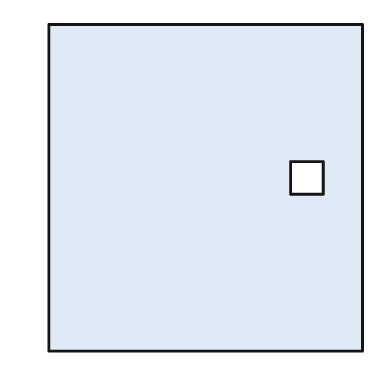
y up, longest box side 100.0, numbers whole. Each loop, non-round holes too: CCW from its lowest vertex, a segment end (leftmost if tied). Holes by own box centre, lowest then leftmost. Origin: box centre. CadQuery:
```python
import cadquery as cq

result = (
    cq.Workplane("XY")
    .moveTo(-48.0, -50.0)
    .lineTo(48.0, -50.0)
    .lineTo(48.0, 50.0)
    .lineTo(-48.0, 50.0)
    .close()
    .moveTo(26.0, -2.0)
    .lineTo(36.0, -2.0)
    .lineTo(36.0, 8.0)
    .lineTo(26.0, 8.0)
    .close()
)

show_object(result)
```